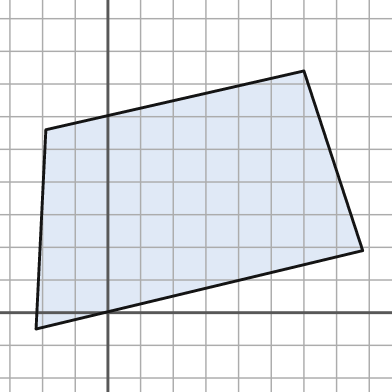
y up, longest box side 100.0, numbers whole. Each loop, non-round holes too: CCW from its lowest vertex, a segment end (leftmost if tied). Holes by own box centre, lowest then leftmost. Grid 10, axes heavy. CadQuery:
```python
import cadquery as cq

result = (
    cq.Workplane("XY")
    .moveTo(-22.0, -5.0)
    .lineTo(78.0, 19.0)
    .lineTo(60.0, 74.0)
    .lineTo(-19.0, 56.0)
    .close()
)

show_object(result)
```